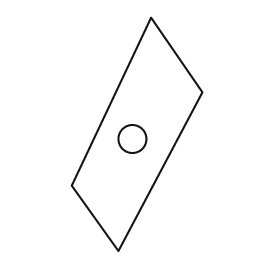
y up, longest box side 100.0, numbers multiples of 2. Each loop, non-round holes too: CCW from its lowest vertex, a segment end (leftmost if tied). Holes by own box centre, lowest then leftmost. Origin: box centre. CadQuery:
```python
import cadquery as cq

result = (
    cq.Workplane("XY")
    .moveTo(-8.0, -50.0)
    .lineTo(28.0, 18.0)
    .lineTo(6.0, 50.0)
    .lineTo(-28.0, -22.0)
    .close()
    .moveTo(-2.0, -2.0)
    .circle(6.0)
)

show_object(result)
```